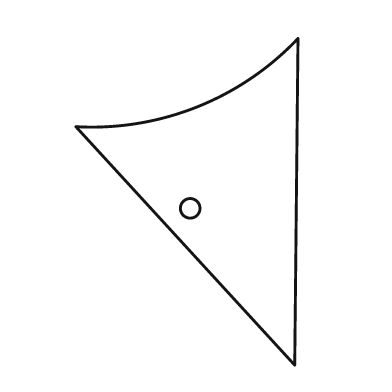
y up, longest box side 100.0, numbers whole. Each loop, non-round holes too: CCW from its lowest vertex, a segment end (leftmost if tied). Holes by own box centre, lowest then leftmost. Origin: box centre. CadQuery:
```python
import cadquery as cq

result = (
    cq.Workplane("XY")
    .moveTo(33.0, -50.0)
    .lineTo(34.0, 50.0)
    .threePointArc((3.0, 29.0), (-34.0, 23.0))
    .close()
    .moveTo(1.0, -2.0)
    .circle(3.0)
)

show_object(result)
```